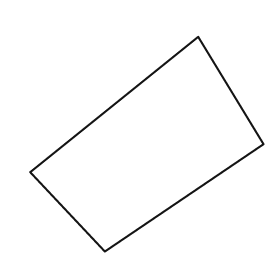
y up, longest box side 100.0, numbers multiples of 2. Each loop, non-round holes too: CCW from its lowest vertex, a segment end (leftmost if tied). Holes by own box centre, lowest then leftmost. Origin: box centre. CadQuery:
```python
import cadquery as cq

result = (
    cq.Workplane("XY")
    .moveTo(-18.0, -46.0)
    .lineTo(50.0, 0.0)
    .lineTo(22.0, 46.0)
    .lineTo(-50.0, -12.0)
    .close()
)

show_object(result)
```